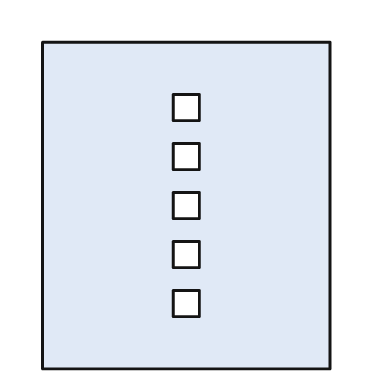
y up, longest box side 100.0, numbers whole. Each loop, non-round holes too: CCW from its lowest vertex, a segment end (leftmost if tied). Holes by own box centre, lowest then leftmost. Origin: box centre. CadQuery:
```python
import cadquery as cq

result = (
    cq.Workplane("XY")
    .moveTo(-44.0, -50.0)
    .lineTo(44.0, -50.0)
    .lineTo(44.0, 50.0)
    .lineTo(-44.0, 50.0)
    .close()
    .moveTo(-4.0, -34.0)
    .lineTo(4.0, -34.0)
    .lineTo(4.0, -26.0)
    .lineTo(-4.0, -26.0)
    .close()
    .moveTo(-4.0, -19.0)
    .lineTo(4.0, -19.0)
    .lineTo(4.0, -11.0)
    .lineTo(-4.0, -11.0)
    .close()
    .moveTo(-4.0, -4.0)
    .lineTo(4.0, -4.0)
    .lineTo(4.0, 4.0)
    .lineTo(-4.0, 4.0)
    .close()
    .moveTo(-4.0, 11.0)
    .lineTo(4.0, 11.0)
    .lineTo(4.0, 19.0)
    .lineTo(-4.0, 19.0)
    .close()
    .moveTo(-4.0, 26.0)
    .lineTo(4.0, 26.0)
    .lineTo(4.0, 34.0)
    .lineTo(-4.0, 34.0)
    .close()
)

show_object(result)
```